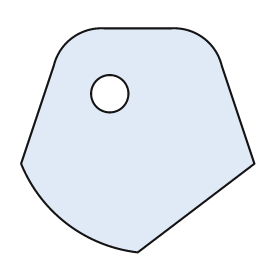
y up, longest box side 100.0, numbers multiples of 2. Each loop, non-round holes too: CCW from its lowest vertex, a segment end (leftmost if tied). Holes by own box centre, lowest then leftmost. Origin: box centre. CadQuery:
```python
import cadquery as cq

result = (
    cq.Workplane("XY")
    .moveTo(0.0, -48.0)
    .lineTo(50.0, -10.0)
    .lineTo(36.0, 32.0)
    .threePointArc((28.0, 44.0), (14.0, 48.0))
    .lineTo(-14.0, 48.0)
    .threePointArc((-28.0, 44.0), (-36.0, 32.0))
    .lineTo(-50.0, -10.0)
    .threePointArc((-30.0, -36.0), (0.0, -48.0))
    .close()
    .moveTo(-12.0, 20.0)
    .circle(8.0)
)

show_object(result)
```